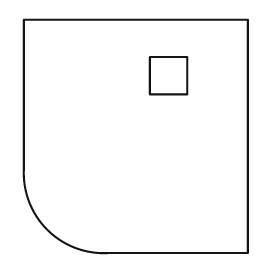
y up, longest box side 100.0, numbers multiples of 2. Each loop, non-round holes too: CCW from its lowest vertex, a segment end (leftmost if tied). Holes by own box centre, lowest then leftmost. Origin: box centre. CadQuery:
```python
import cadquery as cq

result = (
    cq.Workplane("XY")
    .moveTo(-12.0, -50.0)
    .lineTo(48.0, -50.0)
    .lineTo(48.0, 50.0)
    .lineTo(-48.0, 50.0)
    .lineTo(-48.0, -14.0)
    .threePointArc((-38.0, -40.0), (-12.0, -50.0))
    .close()
    .moveTo(6.0, 18.0)
    .lineTo(22.0, 18.0)
    .lineTo(22.0, 34.0)
    .lineTo(6.0, 34.0)
    .close()
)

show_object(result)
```